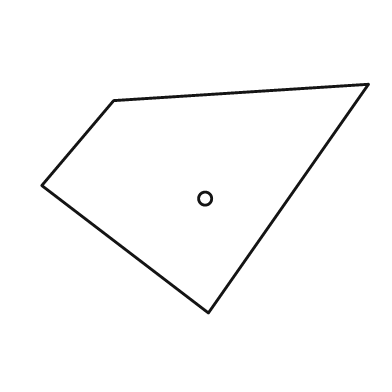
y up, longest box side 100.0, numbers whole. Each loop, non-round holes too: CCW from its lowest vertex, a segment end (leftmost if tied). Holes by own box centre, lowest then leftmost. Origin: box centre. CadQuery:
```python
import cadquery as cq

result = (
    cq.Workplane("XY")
    .moveTo(1.0, -35.0)
    .lineTo(50.0, 35.0)
    .lineTo(-28.0, 30.0)
    .lineTo(-50.0, 4.0)
    .close()
    .moveTo(0.0, 0.0)
    .circle(2.0)
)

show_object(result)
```